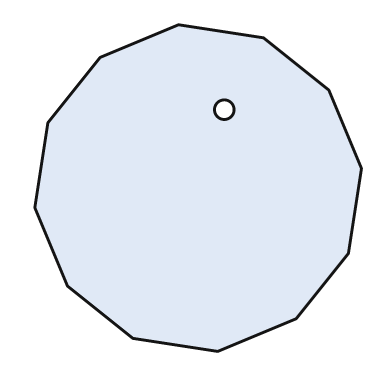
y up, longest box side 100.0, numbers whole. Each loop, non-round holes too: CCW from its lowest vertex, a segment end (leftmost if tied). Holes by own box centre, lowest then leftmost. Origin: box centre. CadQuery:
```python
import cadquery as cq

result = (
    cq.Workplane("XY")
    .moveTo(6.0, -50.0)
    .lineTo(30.0, -40.0)
    .lineTo(46.0, -20.0)
    .lineTo(50.0, 6.0)
    .lineTo(40.0, 30.0)
    .lineTo(20.0, 46.0)
    .lineTo(-6.0, 50.0)
    .lineTo(-30.0, 40.0)
    .lineTo(-46.0, 20.0)
    .lineTo(-50.0, -6.0)
    .lineTo(-40.0, -30.0)
    .lineTo(-20.0, -46.0)
    .close()
    .moveTo(8.0, 24.0)
    .circle(3.0)
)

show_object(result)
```